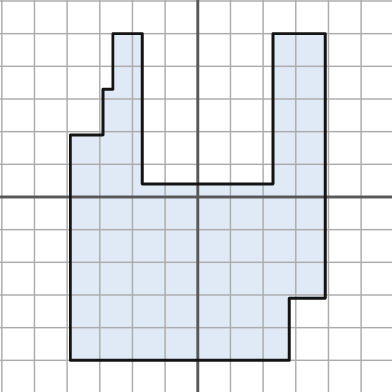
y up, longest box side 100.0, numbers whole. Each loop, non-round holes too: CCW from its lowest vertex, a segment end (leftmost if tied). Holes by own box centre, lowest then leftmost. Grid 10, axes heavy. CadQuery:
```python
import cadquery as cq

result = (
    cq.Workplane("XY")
    .moveTo(-39.0, -50.0)
    .lineTo(28.0, -50.0)
    .lineTo(28.0, -31.0)
    .lineTo(39.0, -31.0)
    .lineTo(39.0, 50.0)
    .lineTo(23.0, 50.0)
    .lineTo(23.0, 4.0)
    .lineTo(-17.0, 4.0)
    .lineTo(-17.0, 50.0)
    .lineTo(-26.0, 50.0)
    .lineTo(-26.0, 33.0)
    .lineTo(-29.0, 33.0)
    .lineTo(-29.0, 19.0)
    .lineTo(-39.0, 19.0)
    .close()
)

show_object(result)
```